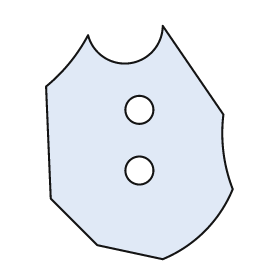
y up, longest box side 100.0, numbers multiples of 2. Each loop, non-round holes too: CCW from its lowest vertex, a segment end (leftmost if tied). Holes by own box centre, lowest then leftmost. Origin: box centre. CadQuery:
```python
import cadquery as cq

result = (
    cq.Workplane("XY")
    .moveTo(10.0, -50.0)
    .threePointArc((28.0, -38.0), (40.0, -20.0))
    .threePointArc((36.0, -4.0), (36.0, 12.0))
    .lineTo(10.0, 50.0)
    .threePointArc((-4.0, 34.0), (-22.0, 46.0))
    .threePointArc((-30.0, 34.0), (-40.0, 24.0))
    .lineTo(-38.0, -24.0)
    .lineTo(-18.0, -44.0)
    .close()
    .moveTo(0.0, -12.0)
    .circle(6.0)
    .moveTo(0.0, 14.0)
    .circle(6.0)
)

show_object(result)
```